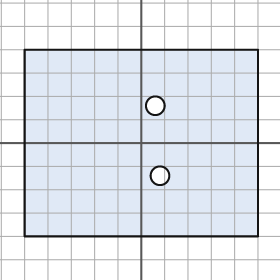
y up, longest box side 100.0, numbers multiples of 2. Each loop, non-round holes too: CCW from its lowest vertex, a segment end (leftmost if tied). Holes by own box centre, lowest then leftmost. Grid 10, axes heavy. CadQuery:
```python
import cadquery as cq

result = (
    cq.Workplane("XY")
    .moveTo(-50.0, -40.0)
    .lineTo(50.0, -40.0)
    .lineTo(50.0, 40.0)
    .lineTo(-50.0, 40.0)
    .close()
    .moveTo(8.0, -14.0)
    .circle(4.0)
    .moveTo(6.0, 16.0)
    .circle(4.0)
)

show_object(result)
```